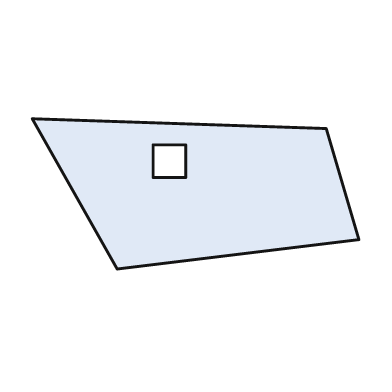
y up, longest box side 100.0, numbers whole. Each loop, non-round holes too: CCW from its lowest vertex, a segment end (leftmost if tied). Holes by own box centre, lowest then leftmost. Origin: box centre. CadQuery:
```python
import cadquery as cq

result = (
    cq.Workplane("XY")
    .moveTo(-24.0, -23.0)
    .lineTo(50.0, -14.0)
    .lineTo(40.0, 20.0)
    .lineTo(-50.0, 23.0)
    .close()
    .moveTo(-13.0, 5.0)
    .lineTo(-3.0, 5.0)
    .lineTo(-3.0, 15.0)
    .lineTo(-13.0, 15.0)
    .close()
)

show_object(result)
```